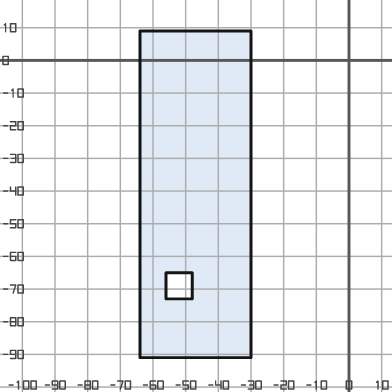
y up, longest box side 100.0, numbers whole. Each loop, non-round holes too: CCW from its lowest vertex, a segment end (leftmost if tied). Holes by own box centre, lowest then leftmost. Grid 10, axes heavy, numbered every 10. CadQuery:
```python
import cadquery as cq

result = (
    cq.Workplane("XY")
    .moveTo(-64.0, -91.0)
    .lineTo(-30.0, -91.0)
    .lineTo(-30.0, 9.0)
    .lineTo(-64.0, 9.0)
    .close()
    .moveTo(-56.0, -73.0)
    .lineTo(-48.0, -73.0)
    .lineTo(-48.0, -65.0)
    .lineTo(-56.0, -65.0)
    .close()
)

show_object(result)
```